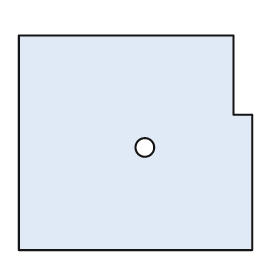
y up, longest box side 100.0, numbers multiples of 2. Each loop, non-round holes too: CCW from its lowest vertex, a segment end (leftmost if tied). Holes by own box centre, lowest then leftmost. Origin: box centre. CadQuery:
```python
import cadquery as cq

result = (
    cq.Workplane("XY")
    .moveTo(-50.0, -46.0)
    .lineTo(50.0, -46.0)
    .lineTo(50.0, 12.0)
    .lineTo(42.0, 12.0)
    .lineTo(42.0, 46.0)
    .lineTo(-50.0, 46.0)
    .close()
    .moveTo(4.0, -2.0)
    .circle(4.0)
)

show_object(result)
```